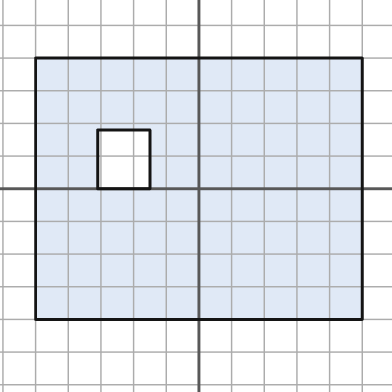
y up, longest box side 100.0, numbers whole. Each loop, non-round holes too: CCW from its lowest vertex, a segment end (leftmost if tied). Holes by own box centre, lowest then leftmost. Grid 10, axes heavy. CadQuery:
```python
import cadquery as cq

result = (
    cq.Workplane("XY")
    .moveTo(-50.0, -40.0)
    .lineTo(50.0, -40.0)
    .lineTo(50.0, 40.0)
    .lineTo(-50.0, 40.0)
    .close()
    .moveTo(-31.0, 0.0)
    .lineTo(-15.0, 0.0)
    .lineTo(-15.0, 18.0)
    .lineTo(-31.0, 18.0)
    .close()
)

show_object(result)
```